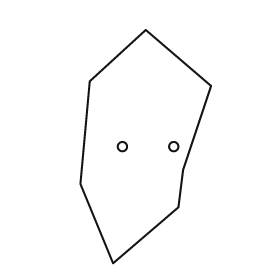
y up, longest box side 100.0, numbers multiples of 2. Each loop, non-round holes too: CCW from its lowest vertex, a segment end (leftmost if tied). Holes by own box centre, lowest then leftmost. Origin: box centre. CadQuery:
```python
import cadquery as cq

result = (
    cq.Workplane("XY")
    .moveTo(-14.0, -50.0)
    .lineTo(14.0, -26.0)
    .lineTo(16.0, -10.0)
    .lineTo(28.0, 26.0)
    .lineTo(0.0, 50.0)
    .lineTo(-24.0, 28.0)
    .lineTo(-28.0, -16.0)
    .close()
    .moveTo(-10.0, 0.0)
    .circle(2.0)
    .moveTo(12.0, 0.0)
    .circle(2.0)
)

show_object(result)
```